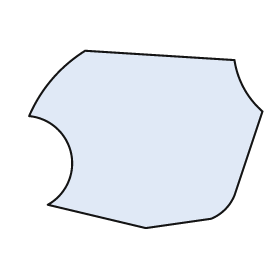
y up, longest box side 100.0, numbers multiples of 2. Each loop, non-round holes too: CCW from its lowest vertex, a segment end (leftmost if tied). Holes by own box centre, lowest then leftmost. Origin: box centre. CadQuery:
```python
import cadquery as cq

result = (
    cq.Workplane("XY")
    .moveTo(0.0, -38.0)
    .lineTo(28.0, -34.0)
    .threePointArc((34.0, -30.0), (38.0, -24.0))
    .lineTo(50.0, 12.0)
    .threePointArc((42.0, 22.0), (38.0, 34.0))
    .lineTo(-26.0, 38.0)
    .threePointArc((-40.0, 26.0), (-50.0, 10.0))
    .threePointArc((-32.0, -6.0), (-42.0, -28.0))
    .close()
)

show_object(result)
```